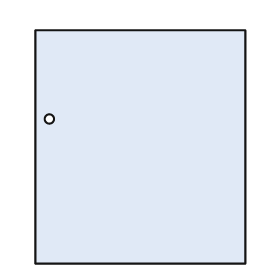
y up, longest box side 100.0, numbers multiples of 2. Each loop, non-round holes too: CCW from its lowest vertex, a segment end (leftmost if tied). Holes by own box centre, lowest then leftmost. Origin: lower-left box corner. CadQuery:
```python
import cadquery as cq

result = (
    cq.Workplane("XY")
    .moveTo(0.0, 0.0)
    .lineTo(90.0, 0.0)
    .lineTo(90.0, 100.0)
    .lineTo(0.0, 100.0)
    .close()
    .moveTo(6.0, 62.0)
    .circle(2.0)
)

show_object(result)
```